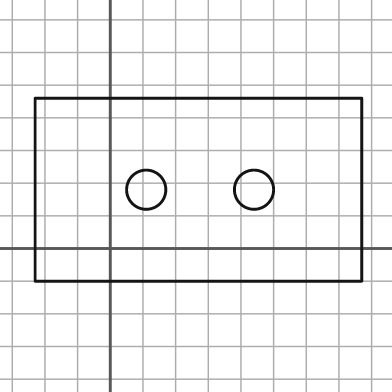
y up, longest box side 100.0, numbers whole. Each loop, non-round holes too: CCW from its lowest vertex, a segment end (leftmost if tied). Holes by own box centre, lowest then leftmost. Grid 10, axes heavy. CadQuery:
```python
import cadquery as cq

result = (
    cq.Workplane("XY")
    .moveTo(-23.0, -10.0)
    .lineTo(77.0, -10.0)
    .lineTo(77.0, 46.0)
    .lineTo(-23.0, 46.0)
    .close()
    .moveTo(11.0, 18.0)
    .circle(6.0)
    .moveTo(44.0, 18.0)
    .circle(6.0)
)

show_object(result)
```